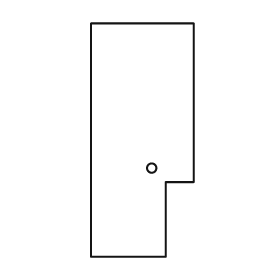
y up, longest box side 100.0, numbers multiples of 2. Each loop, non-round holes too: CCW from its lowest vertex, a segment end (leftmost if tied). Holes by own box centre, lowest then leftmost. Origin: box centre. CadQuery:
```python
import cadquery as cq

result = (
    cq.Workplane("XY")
    .moveTo(-22.0, -50.0)
    .lineTo(10.0, -50.0)
    .lineTo(10.0, -18.0)
    .lineTo(22.0, -18.0)
    .lineTo(22.0, 50.0)
    .lineTo(-22.0, 50.0)
    .close()
    .moveTo(4.0, -12.0)
    .circle(2.0)
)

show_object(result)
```